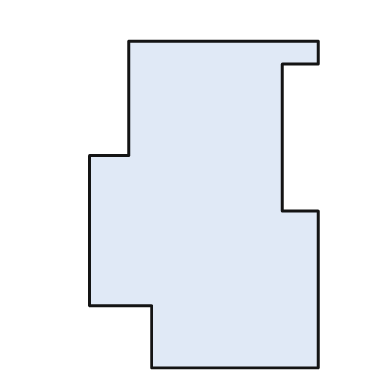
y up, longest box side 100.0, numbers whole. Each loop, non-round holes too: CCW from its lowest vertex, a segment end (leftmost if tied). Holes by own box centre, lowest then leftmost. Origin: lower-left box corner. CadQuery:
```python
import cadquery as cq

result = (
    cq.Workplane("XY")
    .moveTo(19.0, 0.0)
    .lineTo(70.0, 0.0)
    .lineTo(70.0, 48.0)
    .lineTo(59.0, 48.0)
    .lineTo(59.0, 93.0)
    .lineTo(70.0, 93.0)
    .lineTo(70.0, 100.0)
    .lineTo(12.0, 100.0)
    .lineTo(12.0, 65.0)
    .lineTo(0.0, 65.0)
    .lineTo(0.0, 19.0)
    .lineTo(19.0, 19.0)
    .close()
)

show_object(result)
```